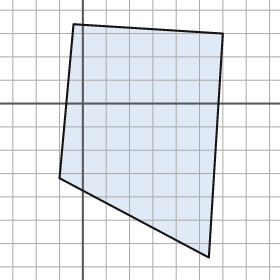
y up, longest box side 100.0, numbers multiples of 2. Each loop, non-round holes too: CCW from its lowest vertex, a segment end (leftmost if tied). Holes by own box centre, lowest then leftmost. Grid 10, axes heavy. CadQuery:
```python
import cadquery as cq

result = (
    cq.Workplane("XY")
    .moveTo(54.0, -66.0)
    .lineTo(60.0, 30.0)
    .lineTo(-4.0, 34.0)
    .lineTo(-10.0, -32.0)
    .close()
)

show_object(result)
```